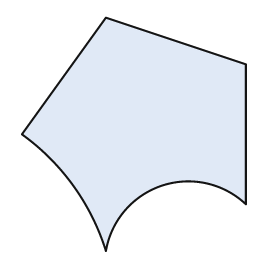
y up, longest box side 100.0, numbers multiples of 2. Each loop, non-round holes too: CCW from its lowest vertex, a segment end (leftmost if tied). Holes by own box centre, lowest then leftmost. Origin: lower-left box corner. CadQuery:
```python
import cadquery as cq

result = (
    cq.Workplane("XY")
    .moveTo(36.0, 0.0)
    .threePointArc((60.0, 28.0), (96.0, 20.0))
    .lineTo(96.0, 80.0)
    .lineTo(36.0, 100.0)
    .lineTo(0.0, 50.0)
    .threePointArc((22.0, 28.0), (36.0, 0.0))
    .close()
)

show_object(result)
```